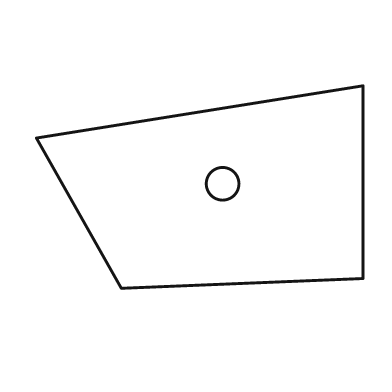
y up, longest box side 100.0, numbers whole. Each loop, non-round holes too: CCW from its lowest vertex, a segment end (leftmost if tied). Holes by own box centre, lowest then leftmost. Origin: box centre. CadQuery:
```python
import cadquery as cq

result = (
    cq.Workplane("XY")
    .moveTo(-24.0, -31.0)
    .lineTo(50.0, -28.0)
    .lineTo(50.0, 31.0)
    .lineTo(-50.0, 15.0)
    .close()
    .moveTo(7.0, 1.0)
    .circle(5.0)
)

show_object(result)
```